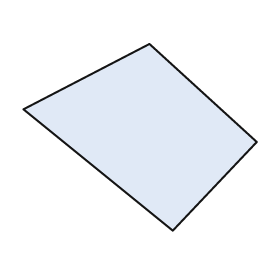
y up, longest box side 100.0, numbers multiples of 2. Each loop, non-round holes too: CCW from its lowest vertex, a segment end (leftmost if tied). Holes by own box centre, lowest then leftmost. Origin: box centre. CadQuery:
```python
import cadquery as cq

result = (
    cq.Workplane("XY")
    .moveTo(14.0, -40.0)
    .lineTo(50.0, -2.0)
    .lineTo(4.0, 40.0)
    .lineTo(-50.0, 12.0)
    .close()
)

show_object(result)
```